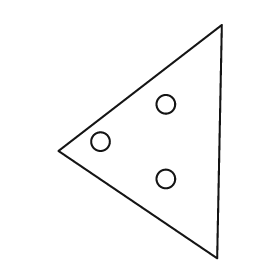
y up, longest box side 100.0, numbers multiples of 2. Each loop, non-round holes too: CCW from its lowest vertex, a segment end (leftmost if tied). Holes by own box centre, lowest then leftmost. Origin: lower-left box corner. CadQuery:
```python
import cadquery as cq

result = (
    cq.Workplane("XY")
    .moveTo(68.0, 0.0)
    .lineTo(70.0, 100.0)
    .lineTo(0.0, 46.0)
    .close()
    .moveTo(46.0, 34.0)
    .circle(4.0)
    .moveTo(18.0, 50.0)
    .circle(4.0)
    .moveTo(46.0, 66.0)
    .circle(4.0)
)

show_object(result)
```